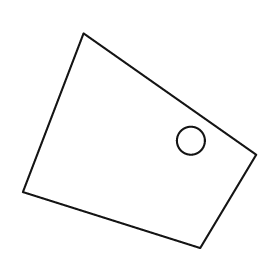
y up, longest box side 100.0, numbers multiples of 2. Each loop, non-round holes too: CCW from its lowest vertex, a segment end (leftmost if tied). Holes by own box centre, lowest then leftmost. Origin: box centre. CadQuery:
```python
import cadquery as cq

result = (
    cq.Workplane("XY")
    .moveTo(26.0, -46.0)
    .lineTo(50.0, -6.0)
    .lineTo(-24.0, 46.0)
    .lineTo(-50.0, -22.0)
    .close()
    .moveTo(22.0, 0.0)
    .circle(6.0)
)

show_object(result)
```